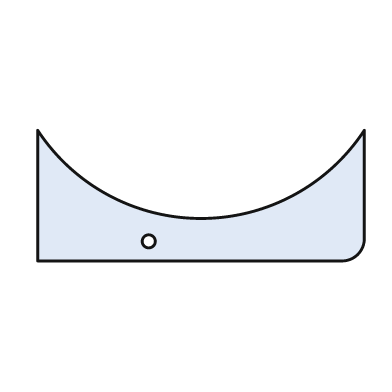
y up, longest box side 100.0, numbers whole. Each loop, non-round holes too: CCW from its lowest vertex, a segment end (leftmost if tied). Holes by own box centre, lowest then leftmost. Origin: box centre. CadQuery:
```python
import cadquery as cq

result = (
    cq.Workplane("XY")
    .moveTo(-50.0, -20.0)
    .lineTo(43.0, -20.0)
    .threePointArc((48.0, -18.0), (50.0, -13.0))
    .lineTo(50.0, 20.0)
    .threePointArc((0.0, -7.0), (-50.0, 20.0))
    .close()
    .moveTo(-16.0, -14.0)
    .circle(2.0)
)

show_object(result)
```